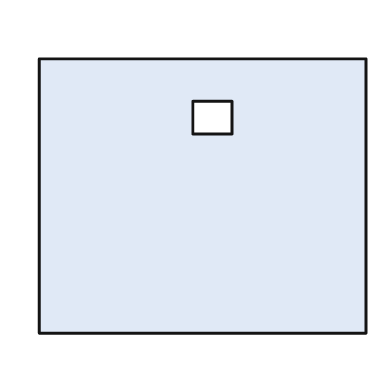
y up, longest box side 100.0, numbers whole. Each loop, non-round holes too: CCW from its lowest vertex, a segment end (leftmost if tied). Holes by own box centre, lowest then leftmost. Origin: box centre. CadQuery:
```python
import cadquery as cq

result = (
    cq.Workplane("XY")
    .moveTo(-50.0, -42.0)
    .lineTo(50.0, -42.0)
    .lineTo(50.0, 42.0)
    .lineTo(-50.0, 42.0)
    .close()
    .moveTo(-3.0, 19.0)
    .lineTo(9.0, 19.0)
    .lineTo(9.0, 29.0)
    .lineTo(-3.0, 29.0)
    .close()
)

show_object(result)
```